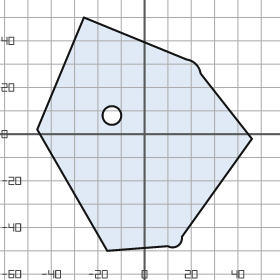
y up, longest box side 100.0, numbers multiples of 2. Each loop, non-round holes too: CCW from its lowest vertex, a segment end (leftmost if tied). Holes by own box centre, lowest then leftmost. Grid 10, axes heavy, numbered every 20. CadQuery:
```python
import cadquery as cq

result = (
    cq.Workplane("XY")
    .moveTo(-16.0, -50.0)
    .lineTo(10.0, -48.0)
    .threePointArc((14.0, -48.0), (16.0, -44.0))
    .lineTo(46.0, -2.0)
    .lineTo(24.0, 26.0)
    .threePointArc((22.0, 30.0), (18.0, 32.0))
    .lineTo(-26.0, 50.0)
    .lineTo(-46.0, 2.0)
    .close()
    .moveTo(-14.0, 8.0)
    .circle(4.0)
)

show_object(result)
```